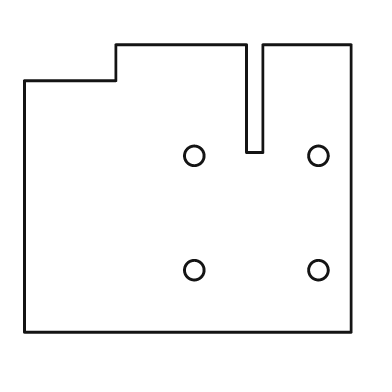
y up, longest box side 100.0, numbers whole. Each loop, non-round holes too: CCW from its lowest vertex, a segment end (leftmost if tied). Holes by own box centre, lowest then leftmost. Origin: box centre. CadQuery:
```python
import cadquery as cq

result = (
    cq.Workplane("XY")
    .moveTo(-50.0, -44.0)
    .lineTo(50.0, -44.0)
    .lineTo(50.0, 44.0)
    .lineTo(23.0, 44.0)
    .lineTo(23.0, 11.0)
    .lineTo(18.0, 11.0)
    .lineTo(18.0, 44.0)
    .lineTo(-22.0, 44.0)
    .lineTo(-22.0, 33.0)
    .lineTo(-50.0, 33.0)
    .close()
    .moveTo(2.0, -25.0)
    .circle(3.0)
    .moveTo(40.0, -25.0)
    .circle(3.0)
    .moveTo(2.0, 10.0)
    .circle(3.0)
    .moveTo(40.0, 10.0)
    .circle(3.0)
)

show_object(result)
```